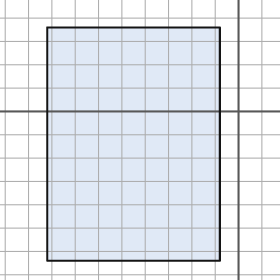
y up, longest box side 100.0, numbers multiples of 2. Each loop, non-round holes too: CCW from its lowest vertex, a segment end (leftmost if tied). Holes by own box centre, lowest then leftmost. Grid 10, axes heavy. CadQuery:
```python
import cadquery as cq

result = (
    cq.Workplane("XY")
    .moveTo(-82.0, -64.0)
    .lineTo(-8.0, -64.0)
    .lineTo(-8.0, 36.0)
    .lineTo(-82.0, 36.0)
    .close()
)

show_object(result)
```